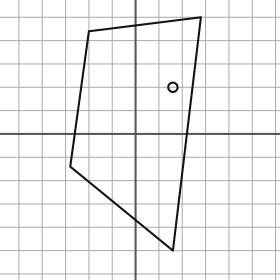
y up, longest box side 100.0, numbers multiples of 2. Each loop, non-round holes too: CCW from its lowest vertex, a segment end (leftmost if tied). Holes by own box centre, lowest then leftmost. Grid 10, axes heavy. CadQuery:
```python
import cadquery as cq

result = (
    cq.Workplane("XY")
    .moveTo(16.0, -50.0)
    .lineTo(28.0, 50.0)
    .lineTo(-20.0, 44.0)
    .lineTo(-28.0, -14.0)
    .close()
    .moveTo(16.0, 20.0)
    .circle(2.0)
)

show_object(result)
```